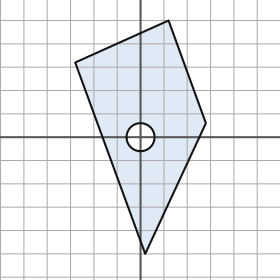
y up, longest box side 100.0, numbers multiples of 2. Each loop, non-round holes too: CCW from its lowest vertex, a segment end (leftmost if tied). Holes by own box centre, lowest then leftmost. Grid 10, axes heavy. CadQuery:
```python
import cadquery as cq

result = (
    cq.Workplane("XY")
    .moveTo(2.0, -50.0)
    .lineTo(28.0, 6.0)
    .lineTo(12.0, 50.0)
    .lineTo(-28.0, 32.0)
    .close()
    .moveTo(0.0, 0.0)
    .circle(6.0)
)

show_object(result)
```